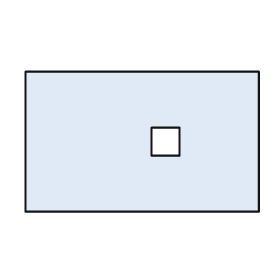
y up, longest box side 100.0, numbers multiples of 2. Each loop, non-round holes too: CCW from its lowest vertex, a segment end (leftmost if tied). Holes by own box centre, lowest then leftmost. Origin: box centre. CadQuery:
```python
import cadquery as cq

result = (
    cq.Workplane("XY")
    .moveTo(-50.0, -30.0)
    .lineTo(50.0, -30.0)
    .lineTo(50.0, 30.0)
    .lineTo(-50.0, 30.0)
    .close()
    .moveTo(4.0, -6.0)
    .lineTo(16.0, -6.0)
    .lineTo(16.0, 6.0)
    .lineTo(4.0, 6.0)
    .close()
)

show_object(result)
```